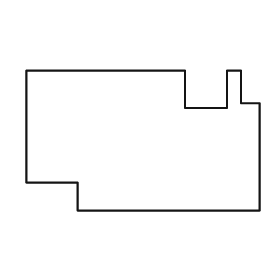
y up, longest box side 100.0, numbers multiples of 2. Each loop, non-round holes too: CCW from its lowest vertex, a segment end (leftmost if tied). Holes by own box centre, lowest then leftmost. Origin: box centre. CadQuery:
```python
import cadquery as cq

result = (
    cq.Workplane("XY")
    .moveTo(-28.0, -30.0)
    .lineTo(50.0, -30.0)
    .lineTo(50.0, 16.0)
    .lineTo(42.0, 16.0)
    .lineTo(42.0, 30.0)
    .lineTo(36.0, 30.0)
    .lineTo(36.0, 14.0)
    .lineTo(18.0, 14.0)
    .lineTo(18.0, 30.0)
    .lineTo(-50.0, 30.0)
    .lineTo(-50.0, -18.0)
    .lineTo(-28.0, -18.0)
    .close()
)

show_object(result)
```